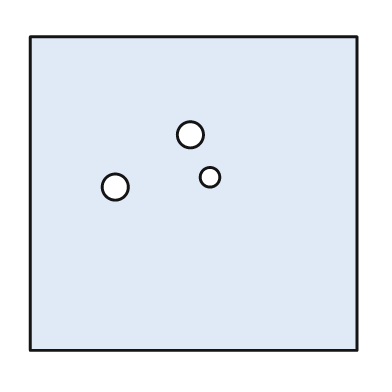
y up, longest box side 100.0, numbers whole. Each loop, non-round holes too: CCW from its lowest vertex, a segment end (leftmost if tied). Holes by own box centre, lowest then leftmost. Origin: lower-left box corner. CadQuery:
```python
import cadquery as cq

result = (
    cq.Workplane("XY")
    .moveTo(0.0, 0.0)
    .lineTo(100.0, 0.0)
    .lineTo(100.0, 96.0)
    .lineTo(0.0, 96.0)
    .close()
    .moveTo(26.0, 50.0)
    .circle(4.0)
    .moveTo(55.0, 53.0)
    .circle(3.0)
    .moveTo(49.0, 66.0)
    .circle(4.0)
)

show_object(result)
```